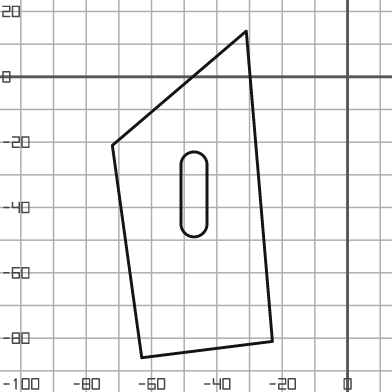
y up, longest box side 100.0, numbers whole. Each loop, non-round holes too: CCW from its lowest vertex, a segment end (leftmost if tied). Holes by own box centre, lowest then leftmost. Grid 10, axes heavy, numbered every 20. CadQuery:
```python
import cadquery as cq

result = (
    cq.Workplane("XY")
    .moveTo(-63.0, -86.0)
    .lineTo(-23.0, -81.0)
    .lineTo(-31.0, 14.0)
    .lineTo(-72.0, -21.0)
    .close()
    .moveTo(-51.0, -45.0)
    .threePointArc((-47.0, -49.0), (-43.0, -45.0))
    .lineTo(-43.0, -27.0)
    .threePointArc((-47.0, -23.0), (-51.0, -27.0))
    .close()
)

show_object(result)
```